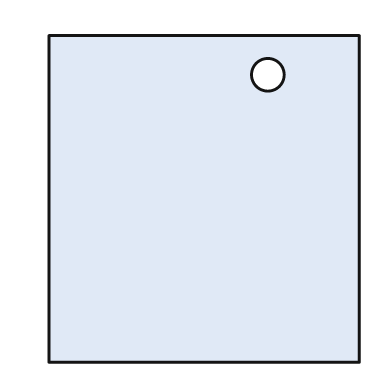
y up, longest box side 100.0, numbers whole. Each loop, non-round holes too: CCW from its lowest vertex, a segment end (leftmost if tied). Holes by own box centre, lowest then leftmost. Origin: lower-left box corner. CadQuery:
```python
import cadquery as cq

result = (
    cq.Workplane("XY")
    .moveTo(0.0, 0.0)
    .lineTo(95.0, 0.0)
    .lineTo(95.0, 100.0)
    .lineTo(0.0, 100.0)
    .close()
    .moveTo(67.0, 88.0)
    .circle(5.0)
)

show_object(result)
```